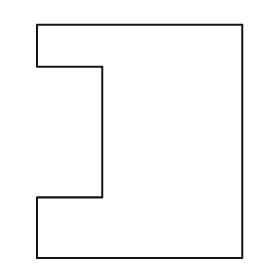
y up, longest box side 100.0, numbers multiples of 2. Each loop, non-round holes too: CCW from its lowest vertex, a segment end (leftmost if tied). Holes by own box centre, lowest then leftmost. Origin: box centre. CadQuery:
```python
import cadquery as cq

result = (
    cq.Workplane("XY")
    .moveTo(-44.0, -50.0)
    .lineTo(44.0, -50.0)
    .lineTo(44.0, 50.0)
    .lineTo(-44.0, 50.0)
    .lineTo(-44.0, 32.0)
    .lineTo(-16.0, 32.0)
    .lineTo(-16.0, -24.0)
    .lineTo(-44.0, -24.0)
    .close()
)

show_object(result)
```